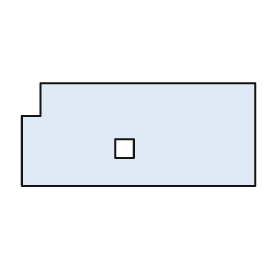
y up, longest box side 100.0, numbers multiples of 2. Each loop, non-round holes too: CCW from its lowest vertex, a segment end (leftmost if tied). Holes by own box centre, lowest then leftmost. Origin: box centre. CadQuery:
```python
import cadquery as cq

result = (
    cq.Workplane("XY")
    .moveTo(-50.0, -22.0)
    .lineTo(50.0, -22.0)
    .lineTo(50.0, 22.0)
    .lineTo(-42.0, 22.0)
    .lineTo(-42.0, 8.0)
    .lineTo(-50.0, 8.0)
    .close()
    .moveTo(-10.0, -10.0)
    .lineTo(-2.0, -10.0)
    .lineTo(-2.0, -2.0)
    .lineTo(-10.0, -2.0)
    .close()
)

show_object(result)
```